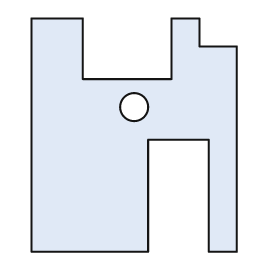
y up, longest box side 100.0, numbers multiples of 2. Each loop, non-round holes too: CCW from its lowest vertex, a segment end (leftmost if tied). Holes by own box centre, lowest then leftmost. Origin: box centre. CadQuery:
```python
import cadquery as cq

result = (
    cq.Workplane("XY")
    .moveTo(-44.0, -50.0)
    .lineTo(6.0, -50.0)
    .lineTo(6.0, -2.0)
    .lineTo(32.0, -2.0)
    .lineTo(32.0, -50.0)
    .lineTo(44.0, -50.0)
    .lineTo(44.0, 38.0)
    .lineTo(28.0, 38.0)
    .lineTo(28.0, 50.0)
    .lineTo(16.0, 50.0)
    .lineTo(16.0, 24.0)
    .lineTo(-22.0, 24.0)
    .lineTo(-22.0, 50.0)
    .lineTo(-44.0, 50.0)
    .close()
    .moveTo(0.0, 12.0)
    .circle(6.0)
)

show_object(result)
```